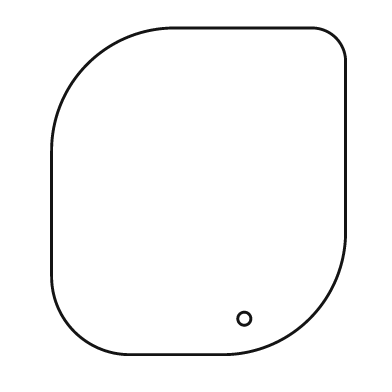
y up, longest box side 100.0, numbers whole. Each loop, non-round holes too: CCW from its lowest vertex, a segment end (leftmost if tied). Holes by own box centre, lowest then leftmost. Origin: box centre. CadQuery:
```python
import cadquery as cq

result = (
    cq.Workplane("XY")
    .moveTo(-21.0, -50.0)
    .lineTo(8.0, -50.0)
    .threePointArc((34.0, -39.0), (45.0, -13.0))
    .lineTo(45.0, 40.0)
    .threePointArc((42.0, 47.0), (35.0, 50.0))
    .lineTo(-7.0, 50.0)
    .threePointArc((-34.0, 39.0), (-45.0, 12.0))
    .lineTo(-45.0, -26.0)
    .threePointArc((-38.0, -43.0), (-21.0, -50.0))
    .close()
    .moveTo(14.0, -39.0)
    .circle(2.0)
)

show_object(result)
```